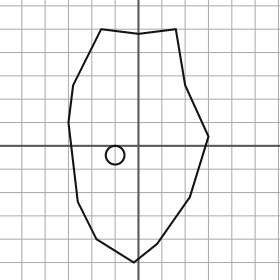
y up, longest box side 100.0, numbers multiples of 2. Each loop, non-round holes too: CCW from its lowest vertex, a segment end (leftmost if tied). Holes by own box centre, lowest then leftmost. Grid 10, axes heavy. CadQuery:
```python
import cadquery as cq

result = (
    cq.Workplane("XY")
    .moveTo(-2.0, -50.0)
    .lineTo(8.0, -42.0)
    .lineTo(22.0, -22.0)
    .lineTo(30.0, 4.0)
    .lineTo(20.0, 26.0)
    .lineTo(16.0, 50.0)
    .lineTo(0.0, 48.0)
    .lineTo(-16.0, 50.0)
    .lineTo(-28.0, 26.0)
    .lineTo(-30.0, 10.0)
    .lineTo(-26.0, -24.0)
    .lineTo(-18.0, -40.0)
    .close()
    .moveTo(-10.0, -4.0)
    .circle(4.0)
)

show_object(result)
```